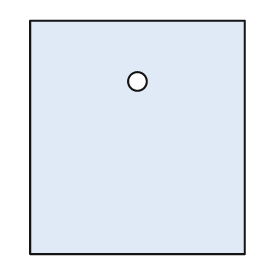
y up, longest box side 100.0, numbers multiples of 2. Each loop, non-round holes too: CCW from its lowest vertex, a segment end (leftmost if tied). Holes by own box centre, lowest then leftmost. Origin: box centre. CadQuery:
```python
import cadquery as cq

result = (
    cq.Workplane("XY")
    .moveTo(-46.0, -50.0)
    .lineTo(46.0, -50.0)
    .lineTo(46.0, 50.0)
    .lineTo(-46.0, 50.0)
    .close()
    .moveTo(0.0, 24.0)
    .circle(4.0)
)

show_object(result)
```